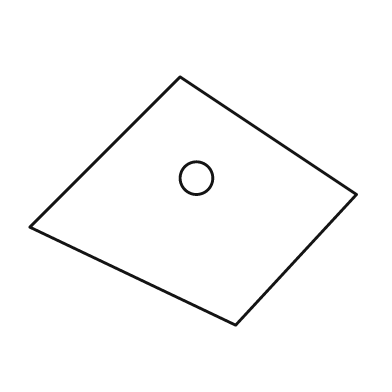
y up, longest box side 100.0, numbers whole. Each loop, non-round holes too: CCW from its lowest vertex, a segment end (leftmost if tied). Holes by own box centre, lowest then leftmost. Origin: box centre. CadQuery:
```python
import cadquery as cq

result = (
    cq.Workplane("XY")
    .moveTo(13.0, -38.0)
    .lineTo(50.0, 2.0)
    .lineTo(-4.0, 38.0)
    .lineTo(-50.0, -8.0)
    .close()
    .moveTo(1.0, 7.0)
    .circle(5.0)
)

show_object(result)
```